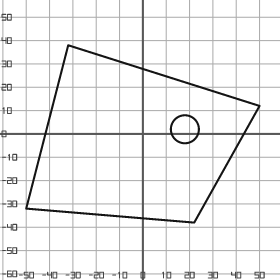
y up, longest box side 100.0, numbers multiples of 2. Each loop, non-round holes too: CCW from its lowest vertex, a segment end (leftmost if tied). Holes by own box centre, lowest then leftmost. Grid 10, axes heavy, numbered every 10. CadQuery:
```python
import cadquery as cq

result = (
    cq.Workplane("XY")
    .moveTo(22.0, -38.0)
    .lineTo(50.0, 12.0)
    .lineTo(-32.0, 38.0)
    .lineTo(-50.0, -32.0)
    .close()
    .moveTo(18.0, 2.0)
    .circle(6.0)
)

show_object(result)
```